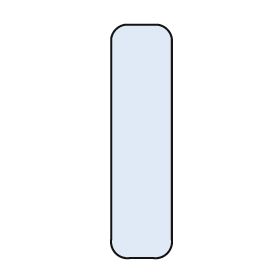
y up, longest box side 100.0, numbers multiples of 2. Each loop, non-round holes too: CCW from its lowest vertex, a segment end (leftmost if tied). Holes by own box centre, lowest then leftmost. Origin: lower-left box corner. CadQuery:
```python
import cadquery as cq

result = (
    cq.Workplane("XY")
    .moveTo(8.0, 0.0)
    .lineTo(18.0, 0.0)
    .threePointArc((24.0, 2.0), (26.0, 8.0))
    .lineTo(26.0, 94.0)
    .threePointArc((24.0, 98.0), (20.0, 100.0))
    .lineTo(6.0, 100.0)
    .threePointArc((2.0, 98.0), (0.0, 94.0))
    .lineTo(0.0, 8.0)
    .threePointArc((2.0, 2.0), (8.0, 0.0))
    .close()
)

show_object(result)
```